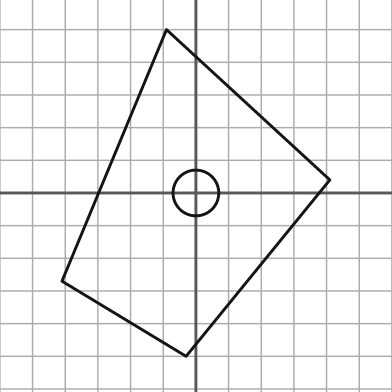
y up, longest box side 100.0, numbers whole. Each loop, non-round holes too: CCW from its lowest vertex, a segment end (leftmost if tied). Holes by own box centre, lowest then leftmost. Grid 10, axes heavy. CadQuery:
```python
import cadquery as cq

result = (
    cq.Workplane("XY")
    .moveTo(-3.0, -50.0)
    .lineTo(41.0, 4.0)
    .lineTo(-9.0, 50.0)
    .lineTo(-41.0, -27.0)
    .close()
    .moveTo(0.0, 0.0)
    .circle(7.0)
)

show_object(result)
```